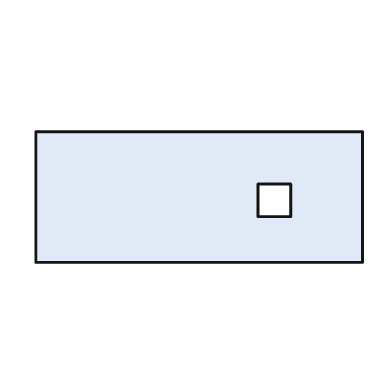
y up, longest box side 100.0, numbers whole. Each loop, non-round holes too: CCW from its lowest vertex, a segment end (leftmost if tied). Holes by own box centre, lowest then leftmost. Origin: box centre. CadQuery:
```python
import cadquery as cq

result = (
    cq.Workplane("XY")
    .moveTo(-50.0, -20.0)
    .lineTo(50.0, -20.0)
    .lineTo(50.0, 20.0)
    .lineTo(-50.0, 20.0)
    .close()
    .moveTo(18.0, -6.0)
    .lineTo(28.0, -6.0)
    .lineTo(28.0, 4.0)
    .lineTo(18.0, 4.0)
    .close()
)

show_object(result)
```